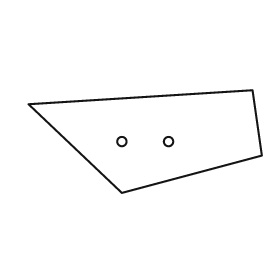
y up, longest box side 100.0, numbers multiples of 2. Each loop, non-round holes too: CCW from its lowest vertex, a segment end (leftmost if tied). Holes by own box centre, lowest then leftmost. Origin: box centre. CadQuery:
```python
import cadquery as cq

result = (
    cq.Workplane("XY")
    .moveTo(-10.0, -22.0)
    .lineTo(50.0, -6.0)
    .lineTo(46.0, 22.0)
    .lineTo(-50.0, 16.0)
    .close()
    .moveTo(-10.0, 0.0)
    .circle(2.0)
    .moveTo(10.0, 0.0)
    .circle(2.0)
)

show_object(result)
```